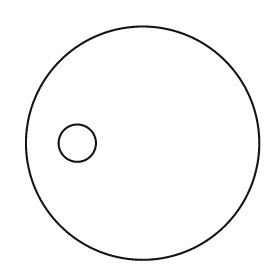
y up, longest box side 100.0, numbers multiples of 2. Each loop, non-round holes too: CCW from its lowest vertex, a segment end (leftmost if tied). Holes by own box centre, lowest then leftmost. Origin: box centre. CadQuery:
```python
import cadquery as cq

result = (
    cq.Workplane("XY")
    .moveTo(0.0, 0.0)
    .circle(50.0)
    .moveTo(-28.0, 0.0)
    .circle(8.0)
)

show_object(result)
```